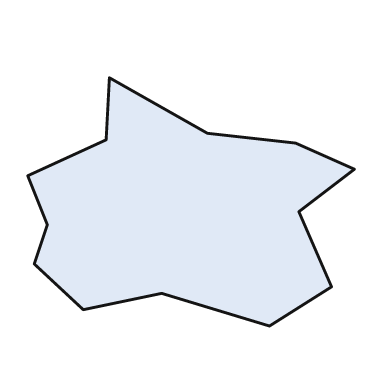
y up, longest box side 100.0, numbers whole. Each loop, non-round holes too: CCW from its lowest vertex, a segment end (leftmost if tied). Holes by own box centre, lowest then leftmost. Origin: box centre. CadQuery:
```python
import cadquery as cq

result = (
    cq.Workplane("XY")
    .moveTo(24.0, -38.0)
    .lineTo(43.0, -26.0)
    .lineTo(33.0, -3.0)
    .lineTo(50.0, 10.0)
    .lineTo(32.0, 18.0)
    .lineTo(5.0, 21.0)
    .lineTo(-25.0, 38.0)
    .lineTo(-26.0, 19.0)
    .lineTo(-50.0, 8.0)
    .lineTo(-44.0, -7.0)
    .lineTo(-48.0, -19.0)
    .lineTo(-33.0, -33.0)
    .lineTo(-9.0, -28.0)
    .close()
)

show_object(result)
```